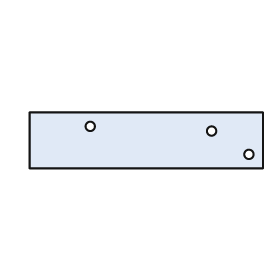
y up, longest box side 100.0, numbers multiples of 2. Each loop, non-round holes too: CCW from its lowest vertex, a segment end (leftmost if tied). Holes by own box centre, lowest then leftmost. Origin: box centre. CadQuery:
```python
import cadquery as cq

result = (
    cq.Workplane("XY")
    .moveTo(-50.0, -12.0)
    .lineTo(50.0, -12.0)
    .lineTo(50.0, 12.0)
    .lineTo(-50.0, 12.0)
    .close()
    .moveTo(44.0, -6.0)
    .circle(2.0)
    .moveTo(28.0, 4.0)
    .circle(2.0)
    .moveTo(-24.0, 6.0)
    .circle(2.0)
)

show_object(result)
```